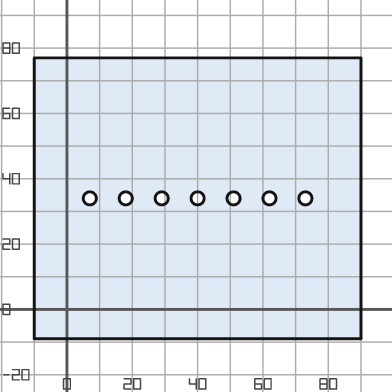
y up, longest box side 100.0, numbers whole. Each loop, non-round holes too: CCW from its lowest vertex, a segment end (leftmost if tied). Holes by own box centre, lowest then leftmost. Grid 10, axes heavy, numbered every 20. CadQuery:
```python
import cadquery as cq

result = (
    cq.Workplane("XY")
    .moveTo(-10.0, -9.0)
    .lineTo(90.0, -9.0)
    .lineTo(90.0, 77.0)
    .lineTo(-10.0, 77.0)
    .close()
    .moveTo(7.0, 34.0)
    .circle(2.0)
    .moveTo(18.0, 34.0)
    .circle(2.0)
    .moveTo(29.0, 34.0)
    .circle(2.0)
    .moveTo(40.0, 34.0)
    .circle(2.0)
    .moveTo(51.0, 34.0)
    .circle(2.0)
    .moveTo(62.0, 34.0)
    .circle(2.0)
    .moveTo(73.0, 34.0)
    .circle(2.0)
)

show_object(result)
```